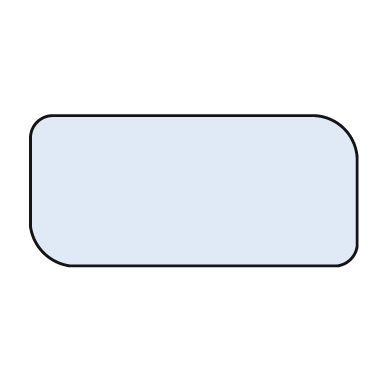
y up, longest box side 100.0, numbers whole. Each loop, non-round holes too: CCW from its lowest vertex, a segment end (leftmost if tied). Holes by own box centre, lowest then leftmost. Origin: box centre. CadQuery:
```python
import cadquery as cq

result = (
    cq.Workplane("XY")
    .moveTo(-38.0, -23.0)
    .lineTo(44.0, -23.0)
    .threePointArc((48.0, -21.0), (50.0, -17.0))
    .lineTo(50.0, 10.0)
    .threePointArc((46.0, 19.0), (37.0, 23.0))
    .lineTo(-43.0, 23.0)
    .threePointArc((-48.0, 21.0), (-50.0, 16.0))
    .lineTo(-50.0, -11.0)
    .threePointArc((-46.0, -19.0), (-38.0, -23.0))
    .close()
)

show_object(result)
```